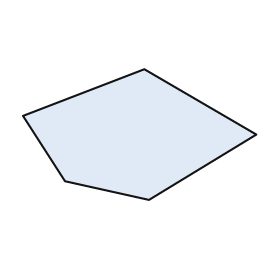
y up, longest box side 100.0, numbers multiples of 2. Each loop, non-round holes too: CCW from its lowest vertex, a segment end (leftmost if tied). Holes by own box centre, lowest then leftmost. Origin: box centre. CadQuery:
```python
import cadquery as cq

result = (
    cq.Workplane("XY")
    .moveTo(4.0, -28.0)
    .lineTo(50.0, 0.0)
    .lineTo(2.0, 28.0)
    .lineTo(-50.0, 8.0)
    .lineTo(-32.0, -20.0)
    .close()
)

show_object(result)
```